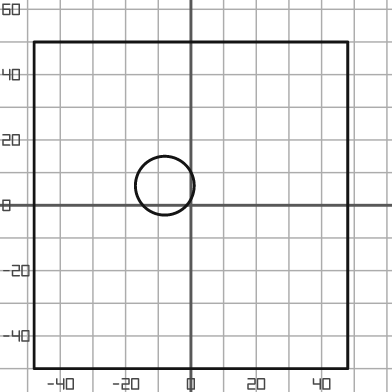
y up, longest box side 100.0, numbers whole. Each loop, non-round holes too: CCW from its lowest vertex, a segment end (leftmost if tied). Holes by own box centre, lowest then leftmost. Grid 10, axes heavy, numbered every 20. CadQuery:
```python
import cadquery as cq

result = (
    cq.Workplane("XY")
    .moveTo(-48.0, -50.0)
    .lineTo(48.0, -50.0)
    .lineTo(48.0, 50.0)
    .lineTo(-48.0, 50.0)
    .close()
    .moveTo(-8.0, 6.0)
    .circle(9.0)
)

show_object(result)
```